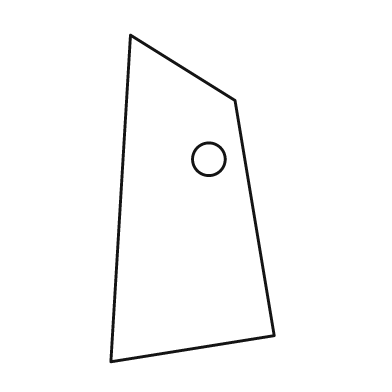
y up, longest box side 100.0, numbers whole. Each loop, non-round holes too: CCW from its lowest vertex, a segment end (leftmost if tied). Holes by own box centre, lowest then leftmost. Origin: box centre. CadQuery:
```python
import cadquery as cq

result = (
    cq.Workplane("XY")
    .moveTo(-25.0, -50.0)
    .lineTo(25.0, -42.0)
    .lineTo(13.0, 30.0)
    .lineTo(-19.0, 50.0)
    .close()
    .moveTo(5.0, 12.0)
    .circle(5.0)
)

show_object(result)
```